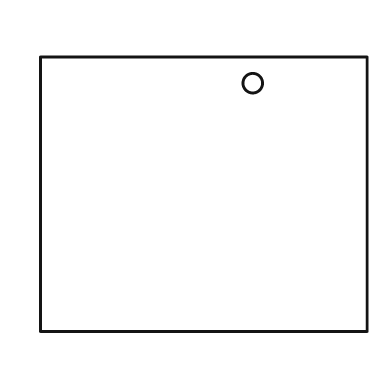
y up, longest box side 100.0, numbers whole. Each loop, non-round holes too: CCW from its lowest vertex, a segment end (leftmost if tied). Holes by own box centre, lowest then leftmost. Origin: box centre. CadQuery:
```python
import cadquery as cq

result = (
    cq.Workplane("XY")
    .moveTo(-50.0, -42.0)
    .lineTo(50.0, -42.0)
    .lineTo(50.0, 42.0)
    .lineTo(-50.0, 42.0)
    .close()
    .moveTo(15.0, 34.0)
    .circle(3.0)
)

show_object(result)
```